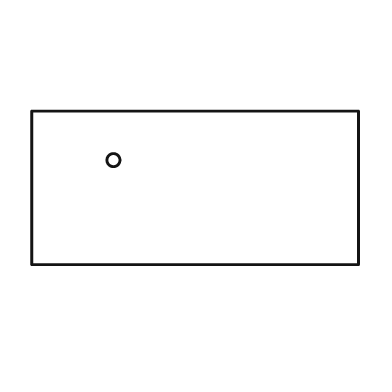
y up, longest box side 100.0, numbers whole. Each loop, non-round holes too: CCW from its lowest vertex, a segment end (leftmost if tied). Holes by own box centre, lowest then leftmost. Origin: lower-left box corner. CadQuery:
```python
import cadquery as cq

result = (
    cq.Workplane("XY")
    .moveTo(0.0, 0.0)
    .lineTo(100.0, 0.0)
    .lineTo(100.0, 47.0)
    .lineTo(0.0, 47.0)
    .close()
    .moveTo(25.0, 32.0)
    .circle(2.0)
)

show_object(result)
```